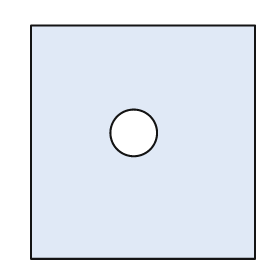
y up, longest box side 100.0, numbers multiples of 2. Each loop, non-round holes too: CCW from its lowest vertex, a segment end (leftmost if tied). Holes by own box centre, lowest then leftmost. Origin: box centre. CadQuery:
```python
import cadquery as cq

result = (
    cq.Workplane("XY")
    .moveTo(-48.0, -50.0)
    .lineTo(48.0, -50.0)
    .lineTo(48.0, 50.0)
    .lineTo(-48.0, 50.0)
    .close()
    .moveTo(-4.0, 4.0)
    .circle(10.0)
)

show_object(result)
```